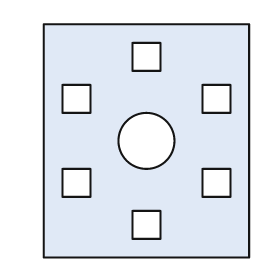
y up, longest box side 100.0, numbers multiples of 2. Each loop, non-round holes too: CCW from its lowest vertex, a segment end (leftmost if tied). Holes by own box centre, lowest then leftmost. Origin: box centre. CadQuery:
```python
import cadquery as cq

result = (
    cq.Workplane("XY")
    .moveTo(-44.0, -50.0)
    .lineTo(44.0, -50.0)
    .lineTo(44.0, 50.0)
    .lineTo(-44.0, 50.0)
    .close()
    .moveTo(-6.0, -42.0)
    .lineTo(6.0, -42.0)
    .lineTo(6.0, -30.0)
    .lineTo(-6.0, -30.0)
    .close()
    .moveTo(-36.0, -24.0)
    .lineTo(-24.0, -24.0)
    .lineTo(-24.0, -12.0)
    .lineTo(-36.0, -12.0)
    .close()
    .moveTo(24.0, -24.0)
    .lineTo(36.0, -24.0)
    .lineTo(36.0, -12.0)
    .lineTo(24.0, -12.0)
    .close()
    .moveTo(0.0, 0.0)
    .circle(12.0)
    .moveTo(-36.0, 12.0)
    .lineTo(-24.0, 12.0)
    .lineTo(-24.0, 24.0)
    .lineTo(-36.0, 24.0)
    .close()
    .moveTo(24.0, 12.0)
    .lineTo(36.0, 12.0)
    .lineTo(36.0, 24.0)
    .lineTo(24.0, 24.0)
    .close()
    .moveTo(-6.0, 30.0)
    .lineTo(6.0, 30.0)
    .lineTo(6.0, 42.0)
    .lineTo(-6.0, 42.0)
    .close()
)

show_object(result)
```